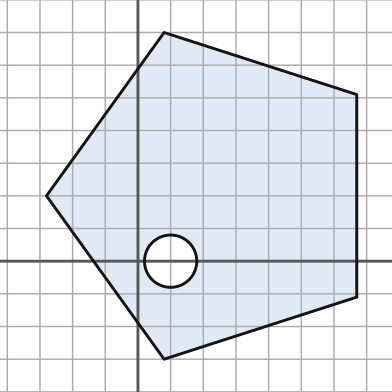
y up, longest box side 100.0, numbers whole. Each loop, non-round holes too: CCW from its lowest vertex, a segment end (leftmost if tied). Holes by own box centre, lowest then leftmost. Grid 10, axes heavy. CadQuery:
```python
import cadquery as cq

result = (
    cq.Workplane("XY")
    .moveTo(8.0, -30.0)
    .lineTo(67.0, -11.0)
    .lineTo(67.0, 51.0)
    .lineTo(8.0, 70.0)
    .lineTo(-28.0, 20.0)
    .close()
    .moveTo(10.0, 0.0)
    .circle(8.0)
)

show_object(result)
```